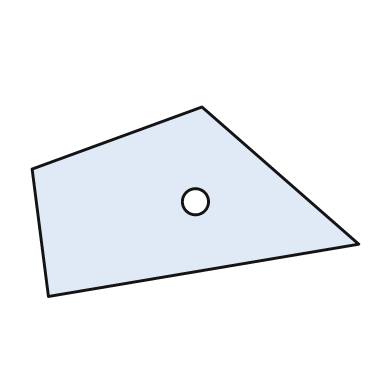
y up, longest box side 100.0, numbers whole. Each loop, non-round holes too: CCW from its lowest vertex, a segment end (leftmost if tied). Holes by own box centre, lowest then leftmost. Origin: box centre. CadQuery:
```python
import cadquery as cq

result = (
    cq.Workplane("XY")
    .moveTo(-45.0, -29.0)
    .lineTo(50.0, -13.0)
    .lineTo(2.0, 29.0)
    .lineTo(-50.0, 10.0)
    .close()
    .moveTo(0.0, 0.0)
    .circle(4.0)
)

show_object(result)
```